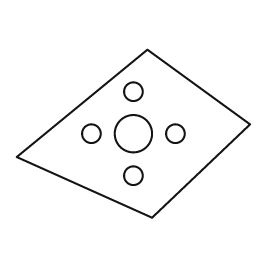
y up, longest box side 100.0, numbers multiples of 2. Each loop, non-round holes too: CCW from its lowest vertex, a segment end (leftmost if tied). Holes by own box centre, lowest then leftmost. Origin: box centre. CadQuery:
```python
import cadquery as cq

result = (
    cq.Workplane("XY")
    .moveTo(8.0, -36.0)
    .lineTo(50.0, 4.0)
    .lineTo(6.0, 36.0)
    .lineTo(-50.0, -10.0)
    .close()
    .moveTo(0.0, -18.0)
    .circle(4.0)
    .moveTo(-18.0, 0.0)
    .circle(4.0)
    .moveTo(0.0, 0.0)
    .circle(8.0)
    .moveTo(18.0, 0.0)
    .circle(4.0)
    .moveTo(0.0, 18.0)
    .circle(4.0)
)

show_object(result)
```